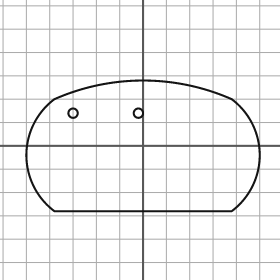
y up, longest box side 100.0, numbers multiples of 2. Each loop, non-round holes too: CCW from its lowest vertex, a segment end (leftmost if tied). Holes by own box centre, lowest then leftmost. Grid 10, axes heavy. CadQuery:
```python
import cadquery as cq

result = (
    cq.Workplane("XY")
    .moveTo(-38.0, -28.0)
    .lineTo(38.0, -28.0)
    .threePointArc((50.0, -4.0), (38.0, 20.0))
    .threePointArc((0.0, 28.0), (-38.0, 20.0))
    .threePointArc((-50.0, -4.0), (-38.0, -28.0))
    .close()
    .moveTo(-30.0, 14.0)
    .circle(2.0)
    .moveTo(-2.0, 14.0)
    .circle(2.0)
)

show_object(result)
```